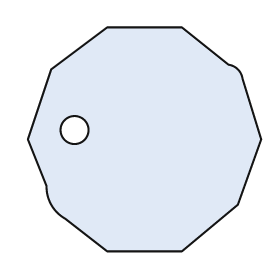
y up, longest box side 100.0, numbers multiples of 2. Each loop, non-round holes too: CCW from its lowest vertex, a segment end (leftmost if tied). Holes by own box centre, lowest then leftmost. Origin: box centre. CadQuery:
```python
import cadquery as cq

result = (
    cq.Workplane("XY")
    .moveTo(-16.0, -48.0)
    .lineTo(16.0, -48.0)
    .lineTo(40.0, -28.0)
    .lineTo(50.0, 0.0)
    .lineTo(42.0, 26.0)
    .threePointArc((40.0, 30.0), (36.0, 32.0))
    .lineTo(16.0, 48.0)
    .lineTo(-16.0, 48.0)
    .lineTo(-40.0, 30.0)
    .lineTo(-50.0, 0.0)
    .lineTo(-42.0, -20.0)
    .threePointArc((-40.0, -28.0), (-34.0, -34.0))
    .close()
    .moveTo(-30.0, 4.0)
    .circle(6.0)
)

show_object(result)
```